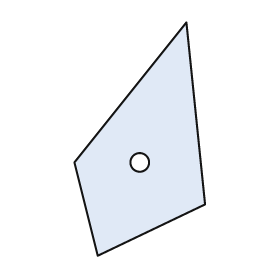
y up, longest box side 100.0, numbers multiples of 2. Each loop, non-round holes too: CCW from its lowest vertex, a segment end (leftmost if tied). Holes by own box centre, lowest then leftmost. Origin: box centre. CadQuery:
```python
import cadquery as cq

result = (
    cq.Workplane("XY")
    .moveTo(-18.0, -50.0)
    .lineTo(28.0, -28.0)
    .lineTo(20.0, 50.0)
    .lineTo(-28.0, -10.0)
    .close()
    .moveTo(0.0, -10.0)
    .circle(4.0)
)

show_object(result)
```